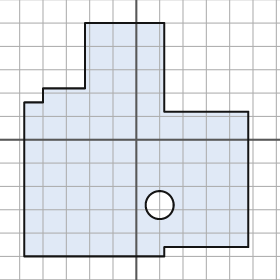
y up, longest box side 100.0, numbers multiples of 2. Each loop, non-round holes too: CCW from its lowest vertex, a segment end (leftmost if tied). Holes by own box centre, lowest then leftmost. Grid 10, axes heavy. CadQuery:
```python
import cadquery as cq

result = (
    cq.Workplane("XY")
    .moveTo(-48.0, -50.0)
    .lineTo(12.0, -50.0)
    .lineTo(12.0, -46.0)
    .lineTo(48.0, -46.0)
    .lineTo(48.0, 12.0)
    .lineTo(12.0, 12.0)
    .lineTo(12.0, 50.0)
    .lineTo(-22.0, 50.0)
    .lineTo(-22.0, 22.0)
    .lineTo(-40.0, 22.0)
    .lineTo(-40.0, 16.0)
    .lineTo(-48.0, 16.0)
    .close()
    .moveTo(10.0, -28.0)
    .circle(6.0)
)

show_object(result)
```